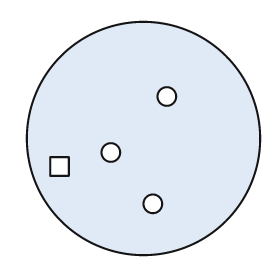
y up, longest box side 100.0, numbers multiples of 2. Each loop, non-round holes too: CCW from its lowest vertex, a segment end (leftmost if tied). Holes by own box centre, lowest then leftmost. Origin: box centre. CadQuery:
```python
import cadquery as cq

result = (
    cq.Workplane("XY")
    .moveTo(0.0, 0.0)
    .circle(50.0)
    .moveTo(4.0, -28.0)
    .circle(4.0)
    .moveTo(-40.0, -16.0)
    .lineTo(-32.0, -16.0)
    .lineTo(-32.0, -8.0)
    .lineTo(-40.0, -8.0)
    .close()
    .moveTo(-14.0, -6.0)
    .circle(4.0)
    .moveTo(10.0, 18.0)
    .circle(4.0)
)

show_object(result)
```